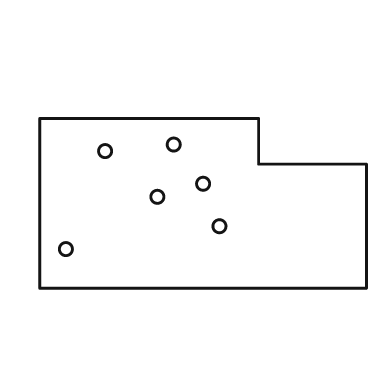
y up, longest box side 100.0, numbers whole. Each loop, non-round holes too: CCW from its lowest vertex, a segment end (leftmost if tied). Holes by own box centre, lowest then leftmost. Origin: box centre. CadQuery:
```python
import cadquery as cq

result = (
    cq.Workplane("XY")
    .moveTo(-50.0, -26.0)
    .lineTo(50.0, -26.0)
    .lineTo(50.0, 12.0)
    .lineTo(17.0, 12.0)
    .lineTo(17.0, 26.0)
    .lineTo(-50.0, 26.0)
    .close()
    .moveTo(-42.0, -14.0)
    .circle(2.0)
    .moveTo(5.0, -7.0)
    .circle(2.0)
    .moveTo(-14.0, 2.0)
    .circle(2.0)
    .moveTo(0.0, 6.0)
    .circle(2.0)
    .moveTo(-30.0, 16.0)
    .circle(2.0)
    .moveTo(-9.0, 18.0)
    .circle(2.0)
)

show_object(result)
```